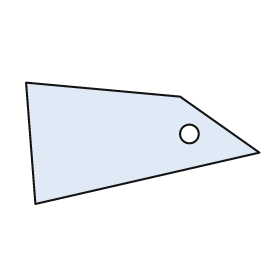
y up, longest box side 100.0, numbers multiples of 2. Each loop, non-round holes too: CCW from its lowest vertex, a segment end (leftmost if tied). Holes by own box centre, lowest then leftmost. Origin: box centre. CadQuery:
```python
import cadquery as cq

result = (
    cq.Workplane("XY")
    .moveTo(-46.0, -26.0)
    .lineTo(50.0, -4.0)
    .lineTo(16.0, 20.0)
    .lineTo(-50.0, 26.0)
    .close()
    .moveTo(20.0, 4.0)
    .circle(4.0)
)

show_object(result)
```